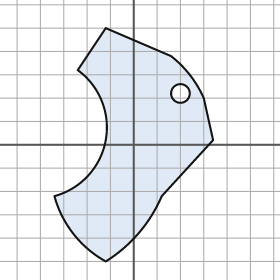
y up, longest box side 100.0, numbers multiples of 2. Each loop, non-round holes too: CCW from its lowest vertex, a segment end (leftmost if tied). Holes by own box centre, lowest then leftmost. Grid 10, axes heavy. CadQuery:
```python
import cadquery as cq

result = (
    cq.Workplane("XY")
    .moveTo(-12.0, -50.0)
    .threePointArc((2.0, -38.0), (12.0, -22.0))
    .lineTo(34.0, 2.0)
    .lineTo(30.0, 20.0)
    .threePointArc((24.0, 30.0), (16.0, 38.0))
    .lineTo(-12.0, 50.0)
    .lineTo(-24.0, 32.0)
    .threePointArc((-12.0, 2.0), (-34.0, -22.0))
    .threePointArc((-26.0, -38.0), (-12.0, -50.0))
    .close()
    .moveTo(20.0, 22.0)
    .circle(4.0)
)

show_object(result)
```